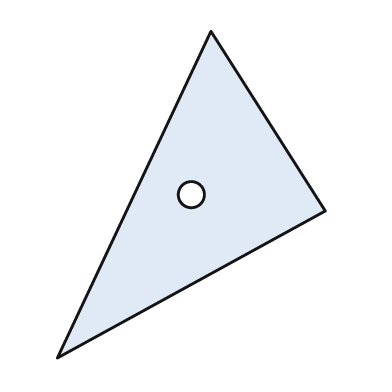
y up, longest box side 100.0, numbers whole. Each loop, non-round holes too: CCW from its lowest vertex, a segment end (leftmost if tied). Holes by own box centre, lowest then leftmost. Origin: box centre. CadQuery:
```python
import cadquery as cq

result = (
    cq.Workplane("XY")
    .moveTo(-41.0, -50.0)
    .lineTo(41.0, -5.0)
    .lineTo(6.0, 50.0)
    .close()
    .moveTo(0.0, 0.0)
    .circle(4.0)
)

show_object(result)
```